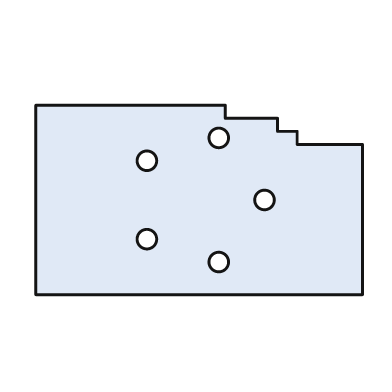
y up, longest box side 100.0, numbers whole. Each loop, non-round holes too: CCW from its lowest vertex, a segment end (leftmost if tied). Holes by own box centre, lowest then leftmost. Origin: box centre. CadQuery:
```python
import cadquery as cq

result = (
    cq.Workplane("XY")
    .moveTo(-50.0, -29.0)
    .lineTo(50.0, -29.0)
    .lineTo(50.0, 17.0)
    .lineTo(30.0, 17.0)
    .lineTo(30.0, 21.0)
    .lineTo(24.0, 21.0)
    .lineTo(24.0, 25.0)
    .lineTo(8.0, 25.0)
    .lineTo(8.0, 29.0)
    .lineTo(-50.0, 29.0)
    .close()
    .moveTo(6.0, -19.0)
    .circle(3.0)
    .moveTo(-16.0, -12.0)
    .circle(3.0)
    .moveTo(20.0, 0.0)
    .circle(3.0)
    .moveTo(-16.0, 12.0)
    .circle(3.0)
    .moveTo(6.0, 19.0)
    .circle(3.0)
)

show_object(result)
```